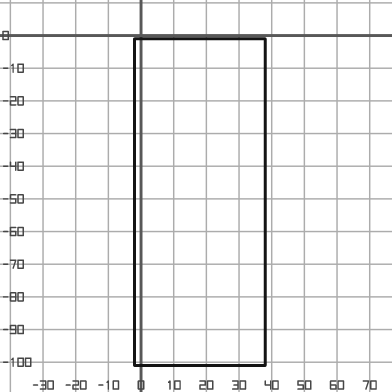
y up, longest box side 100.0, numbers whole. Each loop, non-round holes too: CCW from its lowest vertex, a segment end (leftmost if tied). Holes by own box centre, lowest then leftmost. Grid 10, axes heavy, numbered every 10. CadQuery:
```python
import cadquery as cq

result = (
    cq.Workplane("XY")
    .moveTo(-2.0, -101.0)
    .lineTo(38.0, -101.0)
    .lineTo(38.0, -1.0)
    .lineTo(-2.0, -1.0)
    .close()
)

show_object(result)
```